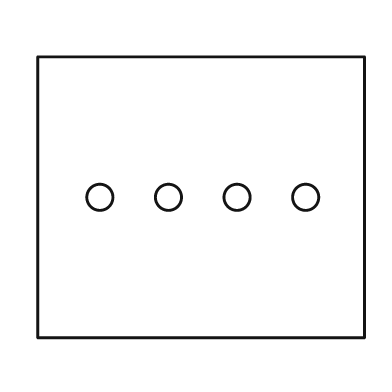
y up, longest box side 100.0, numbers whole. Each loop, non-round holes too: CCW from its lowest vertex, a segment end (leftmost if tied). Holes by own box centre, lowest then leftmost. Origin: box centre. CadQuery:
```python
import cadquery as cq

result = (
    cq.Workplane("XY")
    .moveTo(-50.0, -43.0)
    .lineTo(50.0, -43.0)
    .lineTo(50.0, 43.0)
    .lineTo(-50.0, 43.0)
    .close()
    .moveTo(-31.0, 0.0)
    .circle(4.0)
    .moveTo(-10.0, 0.0)
    .circle(4.0)
    .moveTo(11.0, 0.0)
    .circle(4.0)
    .moveTo(32.0, 0.0)
    .circle(4.0)
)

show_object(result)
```